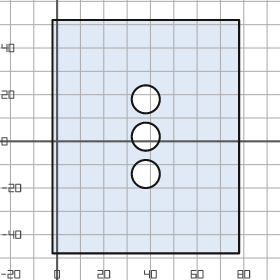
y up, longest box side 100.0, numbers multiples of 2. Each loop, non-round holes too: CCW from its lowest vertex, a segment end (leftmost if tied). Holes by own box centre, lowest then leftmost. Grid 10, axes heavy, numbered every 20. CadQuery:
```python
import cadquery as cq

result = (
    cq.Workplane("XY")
    .moveTo(-2.0, -48.0)
    .lineTo(78.0, -48.0)
    .lineTo(78.0, 52.0)
    .lineTo(-2.0, 52.0)
    .close()
    .moveTo(38.0, -14.0)
    .circle(6.0)
    .moveTo(38.0, 2.0)
    .circle(6.0)
    .moveTo(38.0, 18.0)
    .circle(6.0)
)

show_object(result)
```